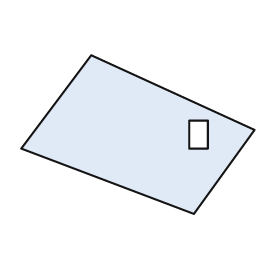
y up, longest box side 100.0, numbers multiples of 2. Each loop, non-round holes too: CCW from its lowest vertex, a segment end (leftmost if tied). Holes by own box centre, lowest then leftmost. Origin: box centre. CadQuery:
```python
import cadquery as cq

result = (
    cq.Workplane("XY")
    .moveTo(24.0, -34.0)
    .lineTo(50.0, 2.0)
    .lineTo(-20.0, 34.0)
    .lineTo(-50.0, -6.0)
    .close()
    .moveTo(22.0, -6.0)
    .lineTo(30.0, -6.0)
    .lineTo(30.0, 6.0)
    .lineTo(22.0, 6.0)
    .close()
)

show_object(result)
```